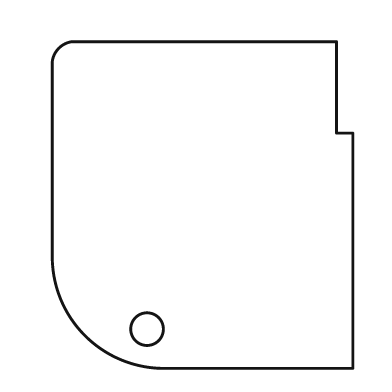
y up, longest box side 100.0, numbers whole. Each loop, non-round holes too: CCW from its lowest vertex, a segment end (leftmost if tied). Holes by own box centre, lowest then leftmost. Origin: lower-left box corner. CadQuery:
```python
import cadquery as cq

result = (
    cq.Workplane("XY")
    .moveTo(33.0, 0.0)
    .lineTo(92.0, 0.0)
    .lineTo(92.0, 72.0)
    .lineTo(87.0, 72.0)
    .lineTo(87.0, 100.0)
    .lineTo(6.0, 100.0)
    .threePointArc((2.0, 98.0), (0.0, 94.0))
    .lineTo(0.0, 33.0)
    .threePointArc((10.0, 10.0), (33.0, 0.0))
    .close()
    .moveTo(29.0, 12.0)
    .circle(5.0)
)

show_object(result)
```